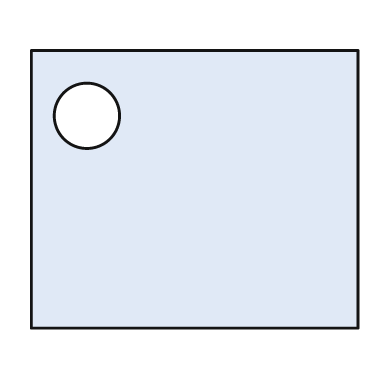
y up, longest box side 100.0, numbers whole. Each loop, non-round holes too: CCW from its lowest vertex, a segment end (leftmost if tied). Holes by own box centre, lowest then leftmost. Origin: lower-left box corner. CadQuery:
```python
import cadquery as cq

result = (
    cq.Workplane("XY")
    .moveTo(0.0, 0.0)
    .lineTo(100.0, 0.0)
    .lineTo(100.0, 85.0)
    .lineTo(0.0, 85.0)
    .close()
    .moveTo(17.0, 65.0)
    .circle(10.0)
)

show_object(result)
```